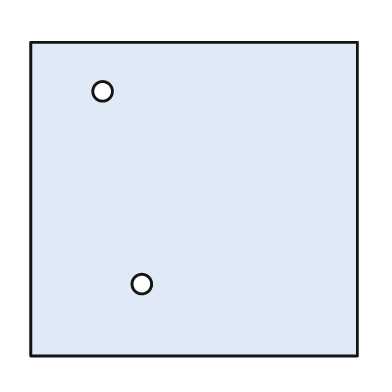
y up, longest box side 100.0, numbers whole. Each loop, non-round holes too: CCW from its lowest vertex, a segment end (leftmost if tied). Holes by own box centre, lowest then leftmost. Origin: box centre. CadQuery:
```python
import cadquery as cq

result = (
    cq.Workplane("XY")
    .moveTo(-50.0, -48.0)
    .lineTo(50.0, -48.0)
    .lineTo(50.0, 48.0)
    .lineTo(-50.0, 48.0)
    .close()
    .moveTo(-16.0, -26.0)
    .circle(3.0)
    .moveTo(-28.0, 33.0)
    .circle(3.0)
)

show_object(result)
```